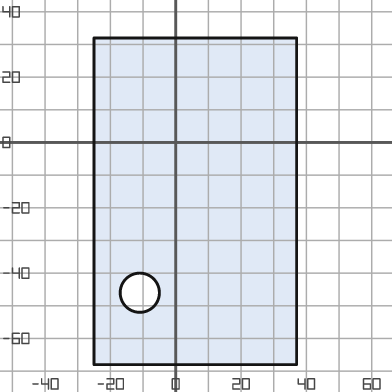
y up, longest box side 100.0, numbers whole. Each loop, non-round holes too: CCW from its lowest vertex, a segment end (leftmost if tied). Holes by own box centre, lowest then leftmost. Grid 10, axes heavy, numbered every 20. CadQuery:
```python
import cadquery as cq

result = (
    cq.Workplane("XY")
    .moveTo(-25.0, -68.0)
    .lineTo(37.0, -68.0)
    .lineTo(37.0, 32.0)
    .lineTo(-25.0, 32.0)
    .close()
    .moveTo(-11.0, -46.0)
    .circle(6.0)
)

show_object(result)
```